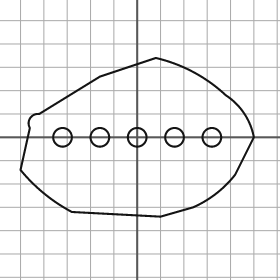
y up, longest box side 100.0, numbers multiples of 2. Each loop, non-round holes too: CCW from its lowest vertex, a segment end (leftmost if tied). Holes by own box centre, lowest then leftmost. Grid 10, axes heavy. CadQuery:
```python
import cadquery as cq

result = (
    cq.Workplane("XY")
    .moveTo(10.0, -34.0)
    .lineTo(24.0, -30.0)
    .threePointArc((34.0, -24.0), (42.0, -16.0))
    .lineTo(50.0, 0.0)
    .threePointArc((46.0, 10.0), (38.0, 18.0))
    .threePointArc((24.0, 28.0), (8.0, 34.0))
    .lineTo(-16.0, 26.0)
    .lineTo(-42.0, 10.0)
    .threePointArc((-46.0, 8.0), (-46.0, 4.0))
    .lineTo(-50.0, -14.0)
    .threePointArc((-40.0, -24.0), (-28.0, -32.0))
    .close()
    .moveTo(-32.0, 0.0)
    .circle(4.0)
    .moveTo(-16.0, 0.0)
    .circle(4.0)
    .moveTo(0.0, 0.0)
    .circle(4.0)
    .moveTo(16.0, 0.0)
    .circle(4.0)
    .moveTo(32.0, 0.0)
    .circle(4.0)
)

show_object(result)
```